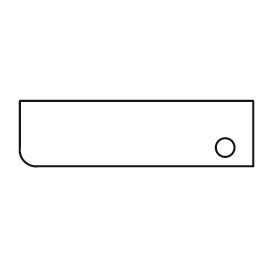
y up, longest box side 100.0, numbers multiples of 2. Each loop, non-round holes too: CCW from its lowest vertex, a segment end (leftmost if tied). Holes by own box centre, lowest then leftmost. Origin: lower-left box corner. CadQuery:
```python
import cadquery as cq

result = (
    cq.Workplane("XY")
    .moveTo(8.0, 0.0)
    .lineTo(100.0, 0.0)
    .lineTo(100.0, 28.0)
    .lineTo(0.0, 28.0)
    .lineTo(0.0, 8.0)
    .threePointArc((2.0, 2.0), (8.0, 0.0))
    .close()
    .moveTo(88.0, 8.0)
    .circle(4.0)
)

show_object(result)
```